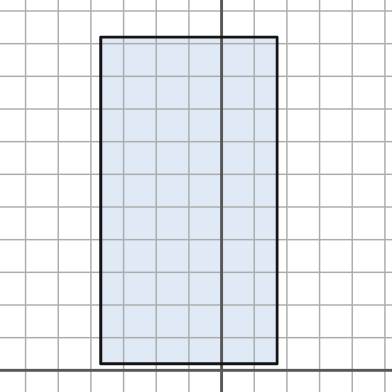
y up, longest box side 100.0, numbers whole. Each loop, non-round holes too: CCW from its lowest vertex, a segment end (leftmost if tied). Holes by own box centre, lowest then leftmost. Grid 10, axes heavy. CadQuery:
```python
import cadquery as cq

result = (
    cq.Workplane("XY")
    .moveTo(-37.0, 2.0)
    .lineTo(17.0, 2.0)
    .lineTo(17.0, 102.0)
    .lineTo(-37.0, 102.0)
    .close()
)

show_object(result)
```